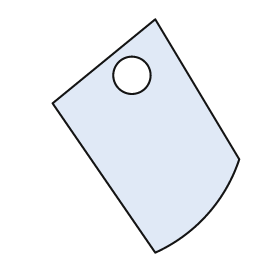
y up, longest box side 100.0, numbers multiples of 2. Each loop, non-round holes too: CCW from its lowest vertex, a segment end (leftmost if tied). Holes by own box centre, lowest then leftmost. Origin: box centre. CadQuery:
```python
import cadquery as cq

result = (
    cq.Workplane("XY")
    .moveTo(4.0, -50.0)
    .threePointArc((26.0, -34.0), (40.0, -10.0))
    .lineTo(4.0, 50.0)
    .lineTo(-40.0, 14.0)
    .close()
    .moveTo(-6.0, 26.0)
    .circle(8.0)
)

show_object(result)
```